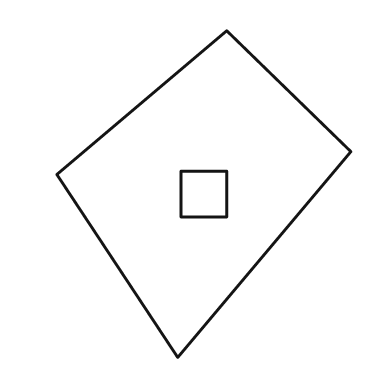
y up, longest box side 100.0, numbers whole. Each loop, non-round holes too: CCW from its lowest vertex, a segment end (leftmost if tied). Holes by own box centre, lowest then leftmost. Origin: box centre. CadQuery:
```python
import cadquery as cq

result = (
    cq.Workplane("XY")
    .moveTo(-8.0, -50.0)
    .lineTo(45.0, 13.0)
    .lineTo(7.0, 50.0)
    .lineTo(-45.0, 6.0)
    .close()
    .moveTo(-7.0, -7.0)
    .lineTo(7.0, -7.0)
    .lineTo(7.0, 7.0)
    .lineTo(-7.0, 7.0)
    .close()
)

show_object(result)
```